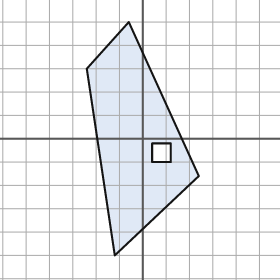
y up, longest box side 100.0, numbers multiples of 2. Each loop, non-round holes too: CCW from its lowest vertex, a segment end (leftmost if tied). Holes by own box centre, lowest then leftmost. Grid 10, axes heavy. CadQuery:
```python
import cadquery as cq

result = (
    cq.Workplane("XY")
    .moveTo(-12.0, -50.0)
    .lineTo(24.0, -16.0)
    .lineTo(-6.0, 50.0)
    .lineTo(-24.0, 30.0)
    .close()
    .moveTo(4.0, -10.0)
    .lineTo(12.0, -10.0)
    .lineTo(12.0, -2.0)
    .lineTo(4.0, -2.0)
    .close()
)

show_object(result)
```